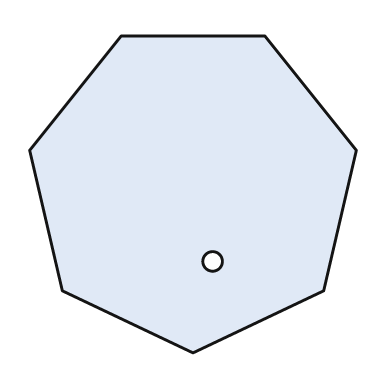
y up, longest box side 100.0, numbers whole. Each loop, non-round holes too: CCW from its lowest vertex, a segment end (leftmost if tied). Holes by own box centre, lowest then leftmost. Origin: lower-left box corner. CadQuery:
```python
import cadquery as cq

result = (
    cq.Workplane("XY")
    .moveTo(50.0, 0.0)
    .lineTo(90.0, 19.0)
    .lineTo(100.0, 62.0)
    .lineTo(72.0, 97.0)
    .lineTo(28.0, 97.0)
    .lineTo(0.0, 62.0)
    .lineTo(10.0, 19.0)
    .close()
    .moveTo(56.0, 28.0)
    .circle(3.0)
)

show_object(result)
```